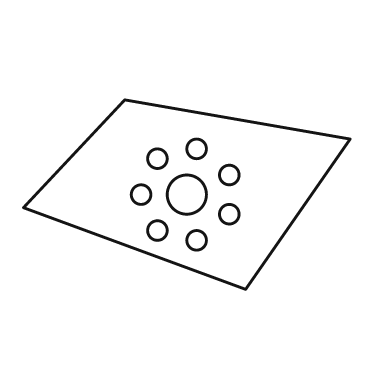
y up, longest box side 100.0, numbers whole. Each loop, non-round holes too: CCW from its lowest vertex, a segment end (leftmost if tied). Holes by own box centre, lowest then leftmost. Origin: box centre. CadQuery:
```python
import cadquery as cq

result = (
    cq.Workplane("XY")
    .moveTo(18.0, -29.0)
    .lineTo(50.0, 17.0)
    .lineTo(-19.0, 29.0)
    .lineTo(-50.0, -4.0)
    .close()
    .moveTo(3.0, -14.0)
    .circle(3.0)
    .moveTo(-9.0, -11.0)
    .circle(3.0)
    .moveTo(13.0, -6.0)
    .circle(3.0)
    .moveTo(-14.0, 0.0)
    .circle(3.0)
    .moveTo(0.0, 0.0)
    .circle(6.0)
    .moveTo(13.0, 6.0)
    .circle(3.0)
    .moveTo(-9.0, 11.0)
    .circle(3.0)
    .moveTo(3.0, 14.0)
    .circle(3.0)
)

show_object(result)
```